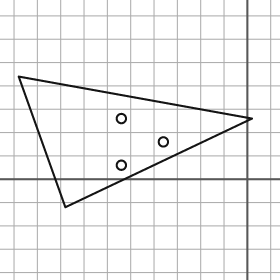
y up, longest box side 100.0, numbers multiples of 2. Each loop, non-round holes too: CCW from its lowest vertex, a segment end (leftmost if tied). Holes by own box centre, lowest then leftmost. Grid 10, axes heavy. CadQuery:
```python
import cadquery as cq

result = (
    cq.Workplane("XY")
    .moveTo(-78.0, -12.0)
    .lineTo(2.0, 26.0)
    .lineTo(-98.0, 44.0)
    .close()
    .moveTo(-54.0, 6.0)
    .circle(2.0)
    .moveTo(-36.0, 16.0)
    .circle(2.0)
    .moveTo(-54.0, 26.0)
    .circle(2.0)
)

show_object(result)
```